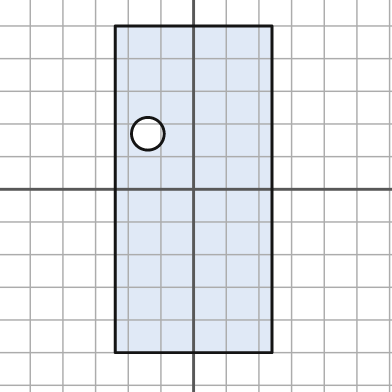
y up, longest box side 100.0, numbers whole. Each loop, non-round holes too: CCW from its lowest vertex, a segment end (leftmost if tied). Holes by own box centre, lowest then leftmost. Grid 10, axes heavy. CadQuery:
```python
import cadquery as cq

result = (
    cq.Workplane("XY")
    .moveTo(-24.0, -50.0)
    .lineTo(24.0, -50.0)
    .lineTo(24.0, 50.0)
    .lineTo(-24.0, 50.0)
    .close()
    .moveTo(-14.0, 17.0)
    .circle(5.0)
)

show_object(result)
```